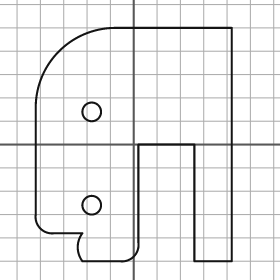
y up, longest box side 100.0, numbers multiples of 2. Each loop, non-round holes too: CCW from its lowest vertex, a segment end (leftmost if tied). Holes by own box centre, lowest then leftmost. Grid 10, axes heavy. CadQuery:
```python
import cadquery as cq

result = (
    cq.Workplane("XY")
    .moveTo(-22.0, -50.0)
    .lineTo(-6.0, -50.0)
    .threePointArc((0.0, -48.0), (2.0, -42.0))
    .lineTo(2.0, 0.0)
    .lineTo(26.0, 0.0)
    .lineTo(26.0, -50.0)
    .lineTo(42.0, -50.0)
    .lineTo(42.0, 50.0)
    .lineTo(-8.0, 50.0)
    .threePointArc((-32.0, 40.0), (-42.0, 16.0))
    .lineTo(-42.0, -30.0)
    .threePointArc((-40.0, -36.0), (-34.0, -38.0))
    .lineTo(-22.0, -38.0)
    .threePointArc((-24.0, -44.0), (-22.0, -50.0))
    .close()
    .moveTo(-18.0, -26.0)
    .circle(4.0)
    .moveTo(-18.0, 14.0)
    .circle(4.0)
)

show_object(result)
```